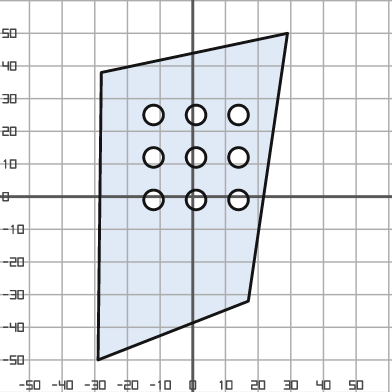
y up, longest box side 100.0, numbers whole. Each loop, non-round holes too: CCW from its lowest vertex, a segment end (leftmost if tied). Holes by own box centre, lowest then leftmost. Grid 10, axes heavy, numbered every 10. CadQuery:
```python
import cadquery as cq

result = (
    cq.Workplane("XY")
    .moveTo(-29.0, -50.0)
    .lineTo(17.0, -32.0)
    .lineTo(29.0, 50.0)
    .lineTo(-28.0, 38.0)
    .close()
    .moveTo(-12.0, -1.0)
    .circle(3.0)
    .moveTo(1.0, -1.0)
    .circle(3.0)
    .moveTo(14.0, -1.0)
    .circle(3.0)
    .moveTo(-12.0, 12.0)
    .circle(3.0)
    .moveTo(1.0, 12.0)
    .circle(3.0)
    .moveTo(14.0, 12.0)
    .circle(3.0)
    .moveTo(-12.0, 25.0)
    .circle(3.0)
    .moveTo(1.0, 25.0)
    .circle(3.0)
    .moveTo(14.0, 25.0)
    .circle(3.0)
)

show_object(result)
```